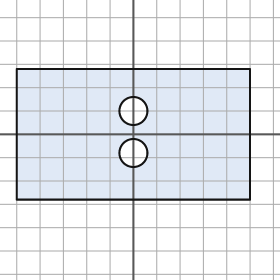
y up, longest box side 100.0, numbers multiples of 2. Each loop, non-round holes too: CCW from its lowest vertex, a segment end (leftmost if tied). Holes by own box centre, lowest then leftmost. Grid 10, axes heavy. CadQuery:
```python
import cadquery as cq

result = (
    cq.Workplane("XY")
    .moveTo(-50.0, -28.0)
    .lineTo(50.0, -28.0)
    .lineTo(50.0, 28.0)
    .lineTo(-50.0, 28.0)
    .close()
    .moveTo(0.0, -8.0)
    .circle(6.0)
    .moveTo(0.0, 10.0)
    .circle(6.0)
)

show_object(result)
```